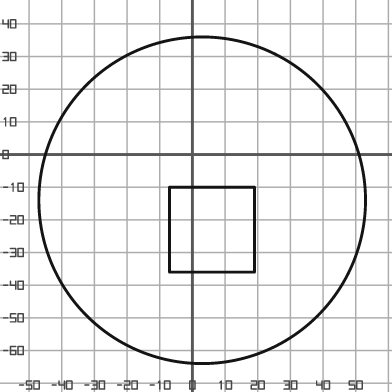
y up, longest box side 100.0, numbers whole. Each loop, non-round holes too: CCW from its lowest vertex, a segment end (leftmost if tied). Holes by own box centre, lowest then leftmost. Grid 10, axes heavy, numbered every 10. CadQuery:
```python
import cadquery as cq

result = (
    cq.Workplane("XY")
    .moveTo(3.0, -14.0)
    .circle(50.0)
    .moveTo(-7.0, -36.0)
    .lineTo(19.0, -36.0)
    .lineTo(19.0, -10.0)
    .lineTo(-7.0, -10.0)
    .close()
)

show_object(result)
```